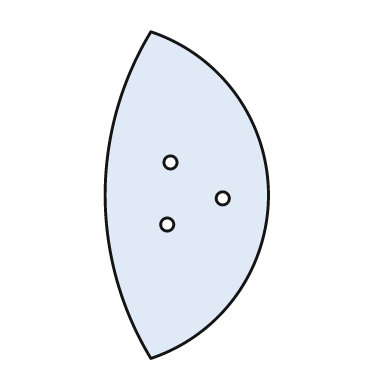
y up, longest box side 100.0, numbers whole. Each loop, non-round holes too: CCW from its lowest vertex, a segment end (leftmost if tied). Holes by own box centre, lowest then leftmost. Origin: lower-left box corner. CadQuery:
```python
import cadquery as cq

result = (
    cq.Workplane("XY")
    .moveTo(14.0, 0.0)
    .threePointArc((50.0, 50.0), (14.0, 100.0))
    .threePointArc((0.0, 50.0), (14.0, 0.0))
    .close()
    .moveTo(19.0, 41.0)
    .circle(2.0)
    .moveTo(36.0, 49.0)
    .circle(2.0)
    .moveTo(20.0, 60.0)
    .circle(2.0)
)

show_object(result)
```